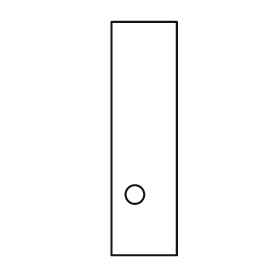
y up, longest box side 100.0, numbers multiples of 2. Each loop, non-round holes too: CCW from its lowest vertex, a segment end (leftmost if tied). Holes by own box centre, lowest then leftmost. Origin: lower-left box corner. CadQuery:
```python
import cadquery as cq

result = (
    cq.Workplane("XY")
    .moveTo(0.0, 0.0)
    .lineTo(28.0, 0.0)
    .lineTo(28.0, 100.0)
    .lineTo(0.0, 100.0)
    .close()
    .moveTo(10.0, 26.0)
    .circle(4.0)
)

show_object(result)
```